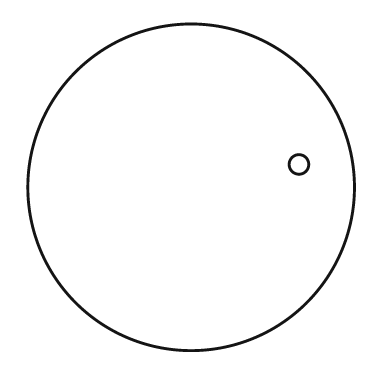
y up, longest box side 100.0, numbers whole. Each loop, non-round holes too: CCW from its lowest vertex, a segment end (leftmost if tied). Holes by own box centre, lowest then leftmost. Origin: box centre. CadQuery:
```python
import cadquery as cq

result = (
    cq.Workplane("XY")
    .moveTo(0.0, 0.0)
    .circle(50.0)
    .moveTo(33.0, 7.0)
    .circle(3.0)
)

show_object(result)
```